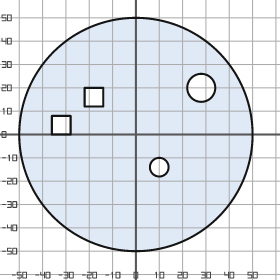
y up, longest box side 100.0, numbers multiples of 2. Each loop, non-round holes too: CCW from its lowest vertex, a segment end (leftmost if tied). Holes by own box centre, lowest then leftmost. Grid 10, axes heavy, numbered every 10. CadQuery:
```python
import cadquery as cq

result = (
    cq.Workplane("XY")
    .moveTo(0.0, 0.0)
    .circle(50.0)
    .moveTo(10.0, -14.0)
    .circle(4.0)
    .moveTo(-36.0, 0.0)
    .lineTo(-28.0, 0.0)
    .lineTo(-28.0, 8.0)
    .lineTo(-36.0, 8.0)
    .close()
    .moveTo(-22.0, 12.0)
    .lineTo(-14.0, 12.0)
    .lineTo(-14.0, 20.0)
    .lineTo(-22.0, 20.0)
    .close()
    .moveTo(28.0, 20.0)
    .circle(6.0)
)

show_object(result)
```